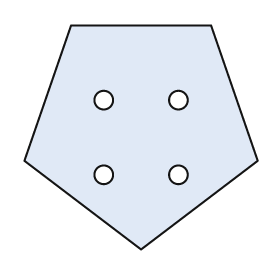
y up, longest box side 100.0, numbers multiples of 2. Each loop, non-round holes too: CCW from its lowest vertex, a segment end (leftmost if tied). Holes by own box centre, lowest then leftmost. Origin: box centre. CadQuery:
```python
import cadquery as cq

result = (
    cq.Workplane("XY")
    .moveTo(0.0, -48.0)
    .lineTo(50.0, -10.0)
    .lineTo(30.0, 48.0)
    .lineTo(-30.0, 48.0)
    .lineTo(-50.0, -10.0)
    .close()
    .moveTo(-16.0, -16.0)
    .circle(4.0)
    .moveTo(16.0, -16.0)
    .circle(4.0)
    .moveTo(-16.0, 16.0)
    .circle(4.0)
    .moveTo(16.0, 16.0)
    .circle(4.0)
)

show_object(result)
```